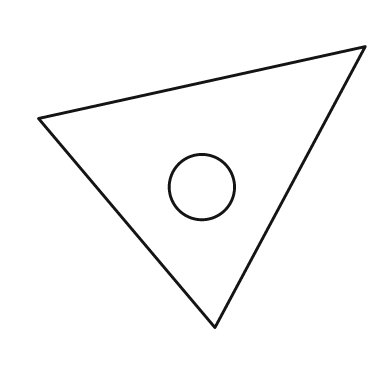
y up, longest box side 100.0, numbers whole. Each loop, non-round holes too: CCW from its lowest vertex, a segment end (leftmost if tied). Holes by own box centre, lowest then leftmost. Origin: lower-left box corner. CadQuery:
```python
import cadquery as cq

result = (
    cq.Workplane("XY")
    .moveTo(54.0, 0.0)
    .lineTo(100.0, 86.0)
    .lineTo(0.0, 64.0)
    .close()
    .moveTo(50.0, 43.0)
    .circle(10.0)
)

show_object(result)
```